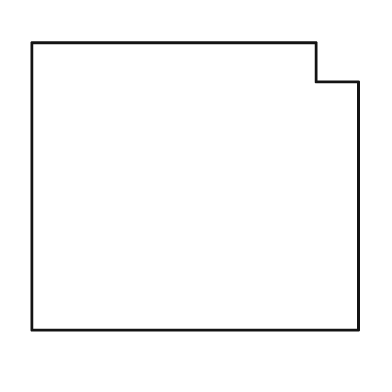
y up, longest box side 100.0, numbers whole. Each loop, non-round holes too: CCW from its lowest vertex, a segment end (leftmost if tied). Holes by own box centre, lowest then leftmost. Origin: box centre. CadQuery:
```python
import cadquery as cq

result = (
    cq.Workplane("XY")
    .moveTo(-50.0, -44.0)
    .lineTo(50.0, -44.0)
    .lineTo(50.0, 32.0)
    .lineTo(37.0, 32.0)
    .lineTo(37.0, 44.0)
    .lineTo(-50.0, 44.0)
    .close()
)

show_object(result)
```